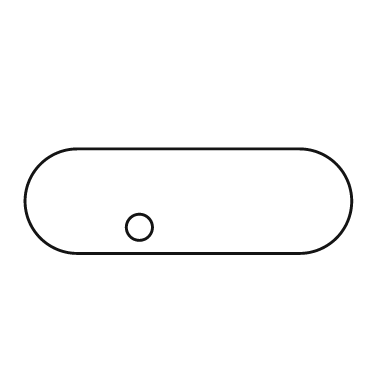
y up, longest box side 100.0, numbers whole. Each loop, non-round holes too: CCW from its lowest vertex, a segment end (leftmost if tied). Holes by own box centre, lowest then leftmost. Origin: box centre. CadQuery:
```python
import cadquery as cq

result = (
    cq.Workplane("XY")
    .moveTo(-34.0, -16.0)
    .lineTo(34.0, -16.0)
    .threePointArc((50.0, 0.0), (34.0, 16.0))
    .lineTo(-34.0, 16.0)
    .threePointArc((-50.0, 0.0), (-34.0, -16.0))
    .close()
    .moveTo(-15.0, -8.0)
    .circle(4.0)
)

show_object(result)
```